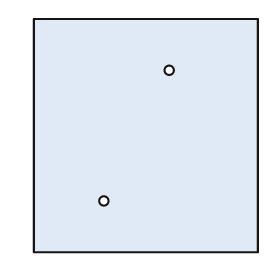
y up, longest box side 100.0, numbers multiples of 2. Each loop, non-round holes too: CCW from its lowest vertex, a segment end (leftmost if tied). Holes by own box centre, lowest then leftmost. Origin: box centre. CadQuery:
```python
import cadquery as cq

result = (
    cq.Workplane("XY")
    .moveTo(-48.0, -50.0)
    .lineTo(48.0, -50.0)
    .lineTo(48.0, 50.0)
    .lineTo(-48.0, 50.0)
    .close()
    .moveTo(-18.0, -28.0)
    .circle(2.0)
    .moveTo(10.0, 28.0)
    .circle(2.0)
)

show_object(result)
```